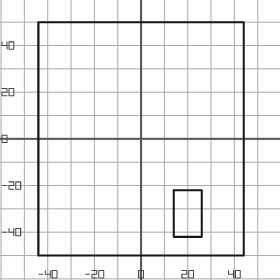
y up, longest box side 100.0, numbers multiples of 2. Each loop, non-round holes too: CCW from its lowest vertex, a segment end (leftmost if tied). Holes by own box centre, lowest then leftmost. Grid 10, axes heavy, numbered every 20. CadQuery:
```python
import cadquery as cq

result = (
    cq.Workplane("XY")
    .moveTo(-44.0, -50.0)
    .lineTo(44.0, -50.0)
    .lineTo(44.0, 50.0)
    .lineTo(-44.0, 50.0)
    .close()
    .moveTo(14.0, -42.0)
    .lineTo(26.0, -42.0)
    .lineTo(26.0, -22.0)
    .lineTo(14.0, -22.0)
    .close()
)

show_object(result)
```